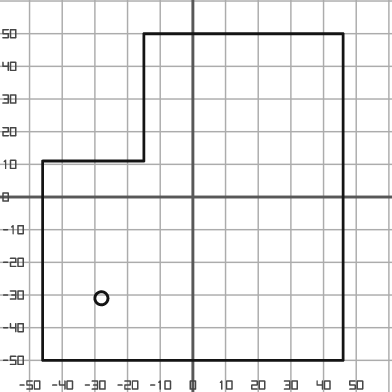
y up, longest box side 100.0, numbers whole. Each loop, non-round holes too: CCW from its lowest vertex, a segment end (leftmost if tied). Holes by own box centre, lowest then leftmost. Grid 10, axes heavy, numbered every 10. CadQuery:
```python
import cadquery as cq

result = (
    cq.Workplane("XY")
    .moveTo(-46.0, -50.0)
    .lineTo(46.0, -50.0)
    .lineTo(46.0, 50.0)
    .lineTo(-15.0, 50.0)
    .lineTo(-15.0, 11.0)
    .lineTo(-46.0, 11.0)
    .close()
    .moveTo(-28.0, -31.0)
    .circle(2.0)
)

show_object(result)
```